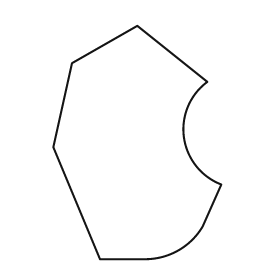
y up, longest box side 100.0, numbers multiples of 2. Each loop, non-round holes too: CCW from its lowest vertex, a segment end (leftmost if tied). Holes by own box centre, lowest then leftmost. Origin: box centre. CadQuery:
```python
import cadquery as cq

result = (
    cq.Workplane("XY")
    .moveTo(-16.0, -50.0)
    .lineTo(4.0, -50.0)
    .threePointArc((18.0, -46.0), (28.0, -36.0))
    .lineTo(36.0, -18.0)
    .threePointArc((20.0, 2.0), (30.0, 26.0))
    .lineTo(0.0, 50.0)
    .lineTo(-28.0, 34.0)
    .lineTo(-36.0, -2.0)
    .close()
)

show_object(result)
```